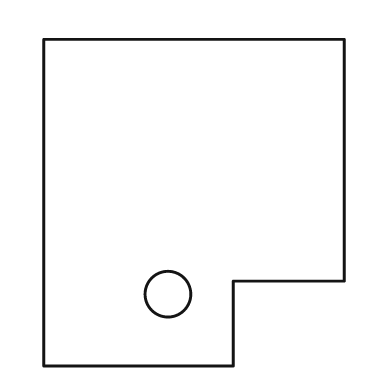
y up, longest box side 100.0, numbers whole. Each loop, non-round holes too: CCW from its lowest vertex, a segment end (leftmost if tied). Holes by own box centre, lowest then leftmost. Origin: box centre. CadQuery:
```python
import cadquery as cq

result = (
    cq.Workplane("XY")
    .moveTo(-46.0, -50.0)
    .lineTo(12.0, -50.0)
    .lineTo(12.0, -24.0)
    .lineTo(46.0, -24.0)
    .lineTo(46.0, 50.0)
    .lineTo(-46.0, 50.0)
    .close()
    .moveTo(-8.0, -28.0)
    .circle(7.0)
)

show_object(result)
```